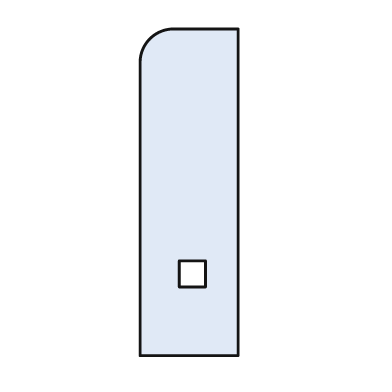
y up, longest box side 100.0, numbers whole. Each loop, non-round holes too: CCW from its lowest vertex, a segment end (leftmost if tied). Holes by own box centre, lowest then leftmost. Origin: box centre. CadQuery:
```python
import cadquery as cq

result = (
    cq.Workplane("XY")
    .moveTo(-15.0, -50.0)
    .lineTo(15.0, -50.0)
    .lineTo(15.0, 50.0)
    .lineTo(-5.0, 50.0)
    .threePointArc((-12.0, 47.0), (-15.0, 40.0))
    .close()
    .moveTo(-3.0, -29.0)
    .lineTo(5.0, -29.0)
    .lineTo(5.0, -21.0)
    .lineTo(-3.0, -21.0)
    .close()
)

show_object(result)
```